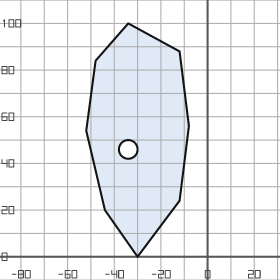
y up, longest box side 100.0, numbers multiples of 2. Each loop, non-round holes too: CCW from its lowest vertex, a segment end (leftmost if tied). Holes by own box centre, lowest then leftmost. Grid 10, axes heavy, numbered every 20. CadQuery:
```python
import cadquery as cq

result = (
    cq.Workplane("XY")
    .moveTo(-30.0, 0.0)
    .lineTo(-12.0, 24.0)
    .lineTo(-8.0, 56.0)
    .lineTo(-12.0, 88.0)
    .lineTo(-34.0, 100.0)
    .lineTo(-48.0, 84.0)
    .lineTo(-52.0, 54.0)
    .lineTo(-44.0, 20.0)
    .close()
    .moveTo(-34.0, 46.0)
    .circle(4.0)
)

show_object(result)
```